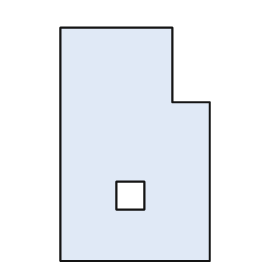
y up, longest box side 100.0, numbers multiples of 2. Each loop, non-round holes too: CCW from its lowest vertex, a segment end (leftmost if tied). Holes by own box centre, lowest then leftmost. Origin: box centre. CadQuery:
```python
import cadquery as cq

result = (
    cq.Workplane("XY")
    .moveTo(-32.0, -50.0)
    .lineTo(32.0, -50.0)
    .lineTo(32.0, 18.0)
    .lineTo(16.0, 18.0)
    .lineTo(16.0, 50.0)
    .lineTo(-32.0, 50.0)
    .close()
    .moveTo(-8.0, -28.0)
    .lineTo(4.0, -28.0)
    .lineTo(4.0, -16.0)
    .lineTo(-8.0, -16.0)
    .close()
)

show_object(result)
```